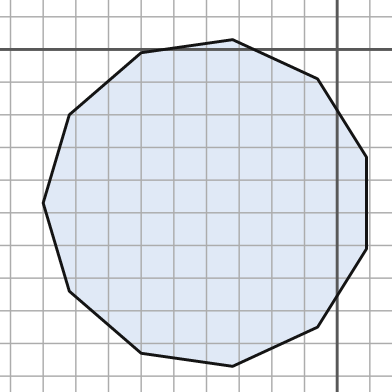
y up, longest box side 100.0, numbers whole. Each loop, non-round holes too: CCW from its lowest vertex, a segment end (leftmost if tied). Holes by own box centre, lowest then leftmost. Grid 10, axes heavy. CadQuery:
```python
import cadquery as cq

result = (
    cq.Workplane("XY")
    .moveTo(-32.0, -97.0)
    .lineTo(-6.0, -85.0)
    .lineTo(9.0, -61.0)
    .lineTo(9.0, -33.0)
    .lineTo(-6.0, -9.0)
    .lineTo(-32.0, 3.0)
    .lineTo(-60.0, -1.0)
    .lineTo(-82.0, -20.0)
    .lineTo(-90.0, -47.0)
    .lineTo(-82.0, -74.0)
    .lineTo(-60.0, -93.0)
    .close()
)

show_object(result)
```